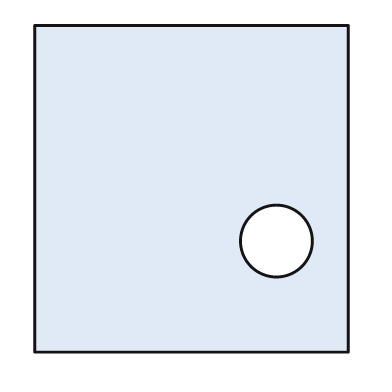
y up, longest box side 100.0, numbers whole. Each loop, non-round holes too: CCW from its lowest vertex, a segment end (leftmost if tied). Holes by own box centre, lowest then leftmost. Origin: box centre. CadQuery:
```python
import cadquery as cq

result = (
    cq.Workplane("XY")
    .moveTo(-48.0, -50.0)
    .lineTo(48.0, -50.0)
    .lineTo(48.0, 50.0)
    .lineTo(-48.0, 50.0)
    .close()
    .moveTo(26.0, -16.0)
    .circle(11.0)
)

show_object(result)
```